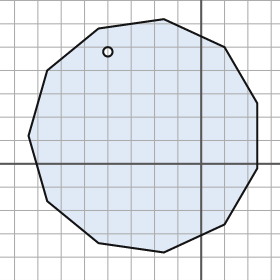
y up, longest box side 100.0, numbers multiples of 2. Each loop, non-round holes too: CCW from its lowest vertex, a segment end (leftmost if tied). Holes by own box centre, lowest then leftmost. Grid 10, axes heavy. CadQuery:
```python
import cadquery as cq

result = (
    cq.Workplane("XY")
    .moveTo(-16.0, -38.0)
    .lineTo(10.0, -26.0)
    .lineTo(24.0, -2.0)
    .lineTo(24.0, 26.0)
    .lineTo(10.0, 50.0)
    .lineTo(-16.0, 62.0)
    .lineTo(-44.0, 58.0)
    .lineTo(-66.0, 40.0)
    .lineTo(-74.0, 12.0)
    .lineTo(-66.0, -16.0)
    .lineTo(-44.0, -34.0)
    .close()
    .moveTo(-40.0, 48.0)
    .circle(2.0)
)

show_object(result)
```